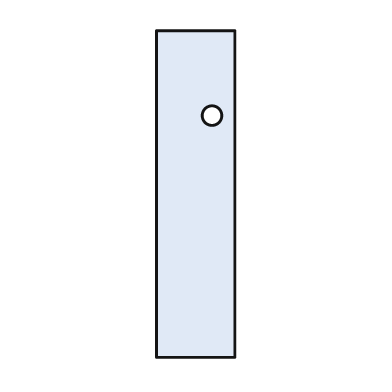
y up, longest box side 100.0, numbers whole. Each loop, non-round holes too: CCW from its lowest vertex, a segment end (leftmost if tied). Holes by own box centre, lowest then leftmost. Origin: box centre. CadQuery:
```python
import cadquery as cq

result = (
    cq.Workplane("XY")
    .moveTo(-12.0, -50.0)
    .lineTo(12.0, -50.0)
    .lineTo(12.0, 50.0)
    .lineTo(-12.0, 50.0)
    .close()
    .moveTo(5.0, 24.0)
    .circle(3.0)
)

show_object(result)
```